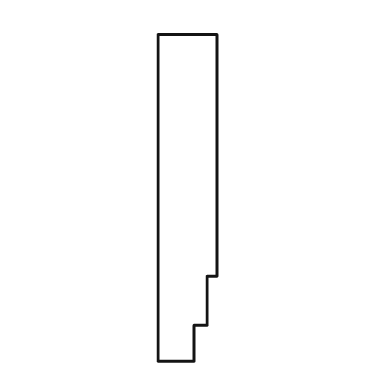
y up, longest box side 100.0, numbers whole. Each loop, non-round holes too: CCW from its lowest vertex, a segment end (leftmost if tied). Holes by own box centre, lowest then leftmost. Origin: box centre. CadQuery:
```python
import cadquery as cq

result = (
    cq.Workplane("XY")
    .moveTo(-9.0, -50.0)
    .lineTo(2.0, -50.0)
    .lineTo(2.0, -39.0)
    .lineTo(6.0, -39.0)
    .lineTo(6.0, -24.0)
    .lineTo(9.0, -24.0)
    .lineTo(9.0, 50.0)
    .lineTo(-9.0, 50.0)
    .close()
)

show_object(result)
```